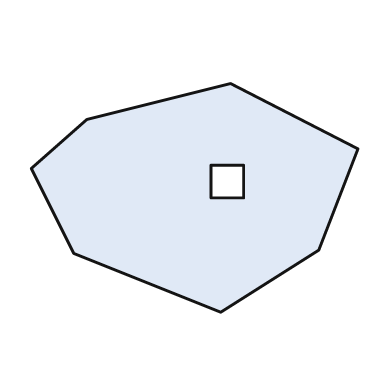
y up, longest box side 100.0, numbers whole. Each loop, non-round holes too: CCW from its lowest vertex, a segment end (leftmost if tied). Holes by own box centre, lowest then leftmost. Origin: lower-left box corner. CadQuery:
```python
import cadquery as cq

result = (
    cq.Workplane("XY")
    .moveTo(58.0, 0.0)
    .lineTo(88.0, 19.0)
    .lineTo(100.0, 50.0)
    .lineTo(61.0, 70.0)
    .lineTo(17.0, 59.0)
    .lineTo(0.0, 44.0)
    .lineTo(13.0, 18.0)
    .close()
    .moveTo(55.0, 35.0)
    .lineTo(65.0, 35.0)
    .lineTo(65.0, 45.0)
    .lineTo(55.0, 45.0)
    .close()
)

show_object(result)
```